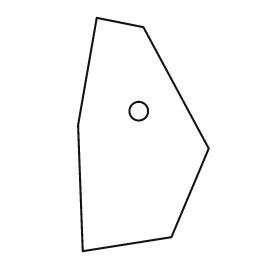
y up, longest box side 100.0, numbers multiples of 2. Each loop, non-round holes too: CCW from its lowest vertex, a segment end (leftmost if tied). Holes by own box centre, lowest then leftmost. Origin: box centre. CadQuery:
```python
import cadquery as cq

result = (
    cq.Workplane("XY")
    .moveTo(-26.0, -50.0)
    .lineTo(12.0, -44.0)
    .lineTo(28.0, -6.0)
    .lineTo(0.0, 46.0)
    .lineTo(-20.0, 50.0)
    .lineTo(-28.0, 4.0)
    .close()
    .moveTo(-2.0, 10.0)
    .circle(4.0)
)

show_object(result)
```